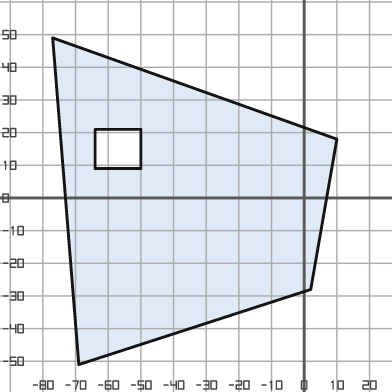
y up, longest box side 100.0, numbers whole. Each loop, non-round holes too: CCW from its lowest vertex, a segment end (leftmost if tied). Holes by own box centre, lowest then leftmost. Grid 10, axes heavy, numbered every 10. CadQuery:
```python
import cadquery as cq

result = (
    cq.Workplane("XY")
    .moveTo(-69.0, -51.0)
    .lineTo(2.0, -28.0)
    .lineTo(10.0, 18.0)
    .lineTo(-77.0, 49.0)
    .close()
    .moveTo(-64.0, 9.0)
    .lineTo(-50.0, 9.0)
    .lineTo(-50.0, 21.0)
    .lineTo(-64.0, 21.0)
    .close()
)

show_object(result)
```